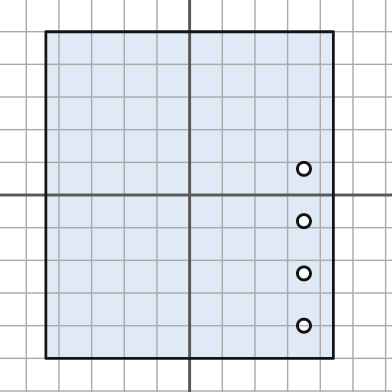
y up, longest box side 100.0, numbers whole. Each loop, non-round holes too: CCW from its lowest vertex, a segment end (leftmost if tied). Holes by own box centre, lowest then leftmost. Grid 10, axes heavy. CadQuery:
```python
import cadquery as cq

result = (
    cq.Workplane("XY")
    .moveTo(-44.0, -50.0)
    .lineTo(44.0, -50.0)
    .lineTo(44.0, 50.0)
    .lineTo(-44.0, 50.0)
    .close()
    .moveTo(35.0, -40.0)
    .circle(2.0)
    .moveTo(35.0, -24.0)
    .circle(2.0)
    .moveTo(35.0, -8.0)
    .circle(2.0)
    .moveTo(35.0, 8.0)
    .circle(2.0)
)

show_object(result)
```